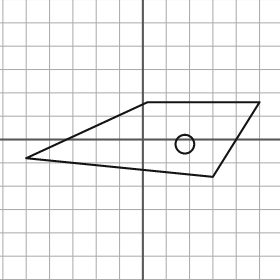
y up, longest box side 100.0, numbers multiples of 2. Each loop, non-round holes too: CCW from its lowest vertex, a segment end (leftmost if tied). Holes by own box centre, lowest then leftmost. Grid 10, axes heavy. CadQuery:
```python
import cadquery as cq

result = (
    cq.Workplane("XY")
    .moveTo(30.0, -16.0)
    .lineTo(50.0, 16.0)
    .lineTo(2.0, 16.0)
    .lineTo(-50.0, -8.0)
    .close()
    .moveTo(18.0, -2.0)
    .circle(4.0)
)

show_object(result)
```